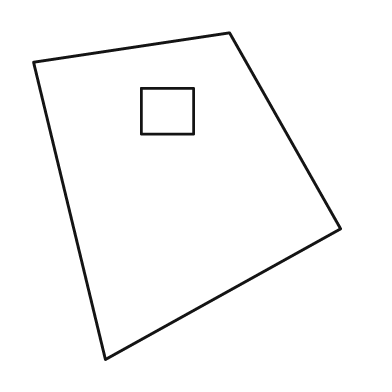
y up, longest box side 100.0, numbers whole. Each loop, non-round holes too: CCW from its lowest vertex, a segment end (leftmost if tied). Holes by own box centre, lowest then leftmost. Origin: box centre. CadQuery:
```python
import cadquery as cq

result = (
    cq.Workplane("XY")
    .moveTo(-25.0, -50.0)
    .lineTo(47.0, -10.0)
    .lineTo(13.0, 50.0)
    .lineTo(-47.0, 41.0)
    .close()
    .moveTo(-14.0, 19.0)
    .lineTo(2.0, 19.0)
    .lineTo(2.0, 33.0)
    .lineTo(-14.0, 33.0)
    .close()
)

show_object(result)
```